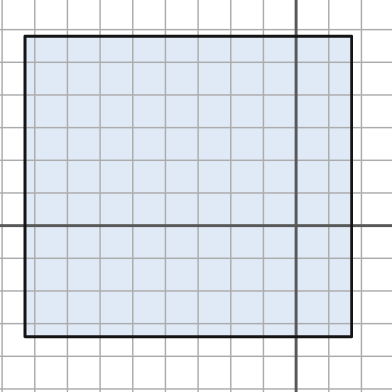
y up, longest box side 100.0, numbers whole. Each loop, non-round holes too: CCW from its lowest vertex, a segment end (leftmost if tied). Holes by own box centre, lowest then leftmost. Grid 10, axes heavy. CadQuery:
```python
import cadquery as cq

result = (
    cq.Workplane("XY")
    .moveTo(-83.0, -34.0)
    .lineTo(17.0, -34.0)
    .lineTo(17.0, 58.0)
    .lineTo(-83.0, 58.0)
    .close()
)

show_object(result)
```